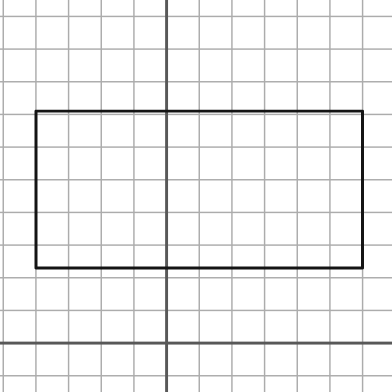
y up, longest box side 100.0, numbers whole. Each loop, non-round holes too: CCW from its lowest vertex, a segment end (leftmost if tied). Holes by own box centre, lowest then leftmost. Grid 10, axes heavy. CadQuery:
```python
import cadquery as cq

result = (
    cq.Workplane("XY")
    .moveTo(-40.0, 23.0)
    .lineTo(60.0, 23.0)
    .lineTo(60.0, 71.0)
    .lineTo(-40.0, 71.0)
    .close()
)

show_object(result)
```